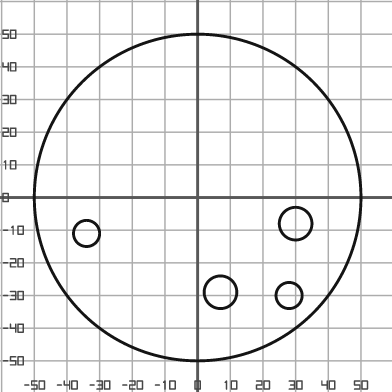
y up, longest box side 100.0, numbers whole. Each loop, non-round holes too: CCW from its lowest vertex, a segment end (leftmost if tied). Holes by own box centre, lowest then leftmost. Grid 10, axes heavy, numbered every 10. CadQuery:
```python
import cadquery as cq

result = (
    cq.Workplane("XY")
    .moveTo(0.0, 0.0)
    .circle(50.0)
    .moveTo(28.0, -30.0)
    .circle(4.0)
    .moveTo(7.0, -29.0)
    .circle(5.0)
    .moveTo(-34.0, -11.0)
    .circle(4.0)
    .moveTo(30.0, -8.0)
    .circle(5.0)
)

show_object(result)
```